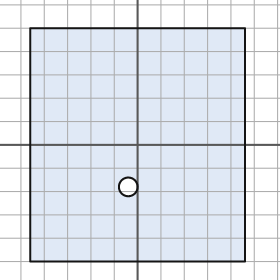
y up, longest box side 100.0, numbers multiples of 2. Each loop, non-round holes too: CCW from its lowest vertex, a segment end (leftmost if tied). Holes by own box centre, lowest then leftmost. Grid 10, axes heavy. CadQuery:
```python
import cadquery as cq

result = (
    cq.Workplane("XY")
    .moveTo(-46.0, -50.0)
    .lineTo(46.0, -50.0)
    .lineTo(46.0, 50.0)
    .lineTo(-46.0, 50.0)
    .close()
    .moveTo(-4.0, -18.0)
    .circle(4.0)
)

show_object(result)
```